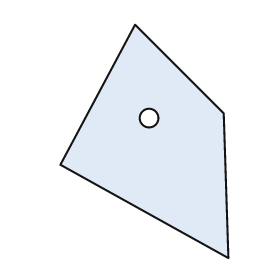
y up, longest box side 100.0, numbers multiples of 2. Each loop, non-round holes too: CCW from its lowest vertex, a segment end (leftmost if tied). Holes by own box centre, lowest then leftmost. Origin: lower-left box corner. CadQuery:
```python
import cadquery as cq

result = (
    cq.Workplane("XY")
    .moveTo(72.0, 0.0)
    .lineTo(70.0, 62.0)
    .lineTo(32.0, 100.0)
    .lineTo(0.0, 40.0)
    .close()
    .moveTo(38.0, 60.0)
    .circle(4.0)
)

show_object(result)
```